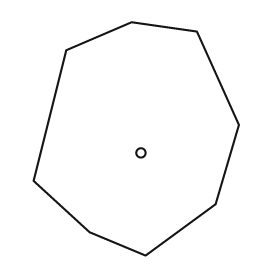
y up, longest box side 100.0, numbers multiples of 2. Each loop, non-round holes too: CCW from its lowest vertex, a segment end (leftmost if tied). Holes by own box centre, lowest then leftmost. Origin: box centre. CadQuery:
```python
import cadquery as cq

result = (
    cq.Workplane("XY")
    .moveTo(4.0, -50.0)
    .lineTo(34.0, -28.0)
    .lineTo(44.0, 6.0)
    .lineTo(26.0, 46.0)
    .lineTo(-2.0, 50.0)
    .lineTo(-30.0, 38.0)
    .lineTo(-44.0, -18.0)
    .lineTo(-20.0, -40.0)
    .close()
    .moveTo(2.0, -6.0)
    .circle(2.0)
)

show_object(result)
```